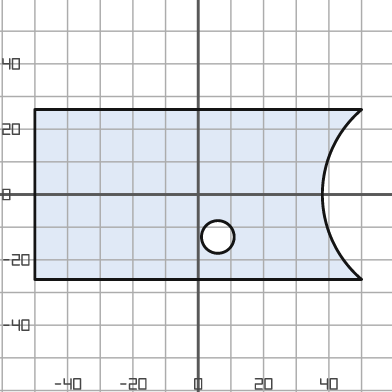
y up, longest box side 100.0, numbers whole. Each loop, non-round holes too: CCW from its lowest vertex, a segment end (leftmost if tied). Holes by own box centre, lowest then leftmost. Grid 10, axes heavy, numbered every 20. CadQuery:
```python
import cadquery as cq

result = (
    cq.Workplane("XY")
    .moveTo(-50.0, -26.0)
    .lineTo(50.0, -26.0)
    .threePointArc((38.0, 0.0), (50.0, 26.0))
    .lineTo(-50.0, 26.0)
    .close()
    .moveTo(6.0, -13.0)
    .circle(5.0)
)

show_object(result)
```